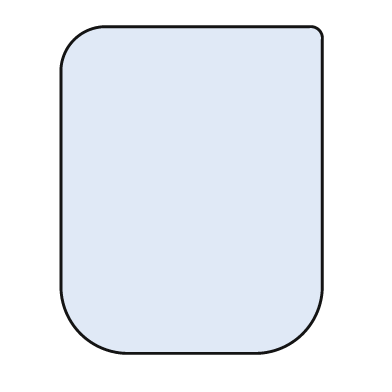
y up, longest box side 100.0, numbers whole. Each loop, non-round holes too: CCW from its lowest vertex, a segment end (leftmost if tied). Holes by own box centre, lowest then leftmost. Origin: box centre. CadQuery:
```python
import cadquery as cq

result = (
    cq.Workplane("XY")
    .moveTo(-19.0, -50.0)
    .lineTo(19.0, -50.0)
    .threePointArc((34.0, -44.0), (40.0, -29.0))
    .lineTo(40.0, 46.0)
    .threePointArc((39.0, 49.0), (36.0, 50.0))
    .lineTo(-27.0, 50.0)
    .threePointArc((-36.0, 46.0), (-40.0, 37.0))
    .lineTo(-40.0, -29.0)
    .threePointArc((-34.0, -44.0), (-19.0, -50.0))
    .close()
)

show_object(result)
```